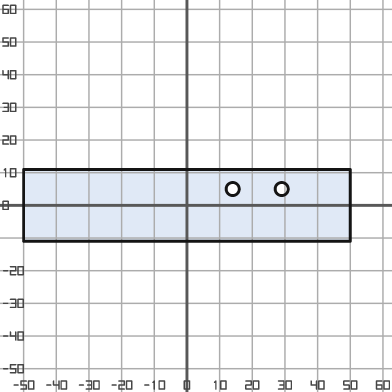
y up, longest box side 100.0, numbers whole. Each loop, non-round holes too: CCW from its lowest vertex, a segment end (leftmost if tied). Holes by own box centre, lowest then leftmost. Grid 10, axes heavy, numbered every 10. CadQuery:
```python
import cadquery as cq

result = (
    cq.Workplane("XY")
    .moveTo(-50.0, -11.0)
    .lineTo(50.0, -11.0)
    .lineTo(50.0, 11.0)
    .lineTo(-50.0, 11.0)
    .close()
    .moveTo(14.0, 5.0)
    .circle(2.0)
    .moveTo(29.0, 5.0)
    .circle(2.0)
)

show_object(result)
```